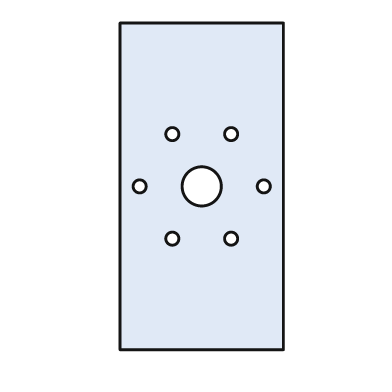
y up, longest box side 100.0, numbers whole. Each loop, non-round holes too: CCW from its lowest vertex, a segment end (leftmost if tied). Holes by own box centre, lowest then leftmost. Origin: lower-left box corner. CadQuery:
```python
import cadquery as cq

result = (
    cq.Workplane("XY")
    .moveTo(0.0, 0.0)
    .lineTo(50.0, 0.0)
    .lineTo(50.0, 100.0)
    .lineTo(0.0, 100.0)
    .close()
    .moveTo(16.0, 34.0)
    .circle(2.0)
    .moveTo(34.0, 34.0)
    .circle(2.0)
    .moveTo(6.0, 50.0)
    .circle(2.0)
    .moveTo(25.0, 50.0)
    .circle(6.0)
    .moveTo(44.0, 50.0)
    .circle(2.0)
    .moveTo(16.0, 66.0)
    .circle(2.0)
    .moveTo(34.0, 66.0)
    .circle(2.0)
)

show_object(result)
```